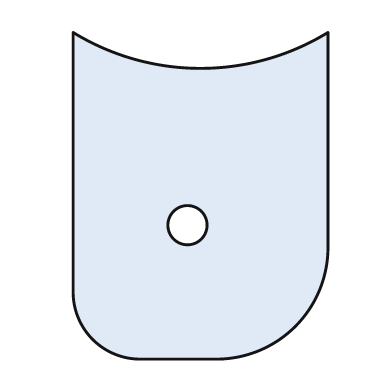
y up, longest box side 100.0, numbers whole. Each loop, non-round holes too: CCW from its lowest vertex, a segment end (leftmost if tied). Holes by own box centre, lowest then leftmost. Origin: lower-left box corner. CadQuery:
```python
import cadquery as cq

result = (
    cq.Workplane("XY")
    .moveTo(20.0, 0.0)
    .lineTo(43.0, 0.0)
    .threePointArc((68.0, 10.0), (78.0, 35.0))
    .lineTo(78.0, 100.0)
    .threePointArc((39.0, 89.0), (0.0, 100.0))
    .lineTo(0.0, 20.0)
    .threePointArc((6.0, 6.0), (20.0, 0.0))
    .close()
    .moveTo(35.0, 41.0)
    .circle(6.0)
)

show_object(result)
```